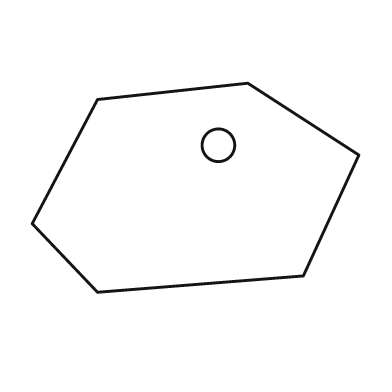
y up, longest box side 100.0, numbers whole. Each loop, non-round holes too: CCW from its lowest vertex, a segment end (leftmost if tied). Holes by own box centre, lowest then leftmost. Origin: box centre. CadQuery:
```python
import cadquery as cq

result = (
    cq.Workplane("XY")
    .moveTo(-30.0, -32.0)
    .lineTo(33.0, -27.0)
    .lineTo(50.0, 10.0)
    .lineTo(16.0, 32.0)
    .lineTo(-30.0, 27.0)
    .lineTo(-50.0, -11.0)
    .close()
    .moveTo(7.0, 13.0)
    .circle(5.0)
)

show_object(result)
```